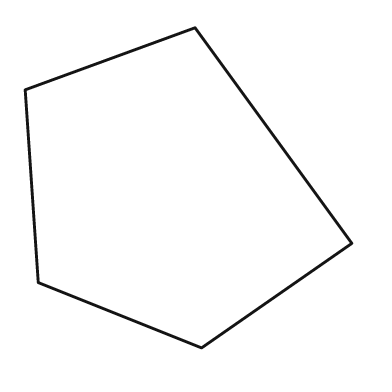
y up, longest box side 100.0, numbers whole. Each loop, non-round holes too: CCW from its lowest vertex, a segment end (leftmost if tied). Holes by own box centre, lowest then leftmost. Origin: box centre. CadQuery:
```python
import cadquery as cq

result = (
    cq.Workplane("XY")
    .moveTo(4.0, -49.0)
    .lineTo(50.0, -17.0)
    .lineTo(2.0, 49.0)
    .lineTo(-50.0, 30.0)
    .lineTo(-46.0, -29.0)
    .close()
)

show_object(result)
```